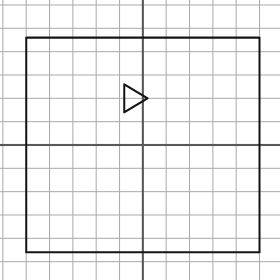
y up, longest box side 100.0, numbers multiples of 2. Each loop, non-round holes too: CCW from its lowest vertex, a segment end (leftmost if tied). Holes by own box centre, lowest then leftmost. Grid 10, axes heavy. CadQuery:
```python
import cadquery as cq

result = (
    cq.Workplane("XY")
    .moveTo(-50.0, -46.0)
    .lineTo(50.0, -46.0)
    .lineTo(50.0, 46.0)
    .lineTo(-50.0, 46.0)
    .close()
    .moveTo(-8.0, 14.0)
    .lineTo(2.0, 20.0)
    .lineTo(-8.0, 26.0)
    .close()
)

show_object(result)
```